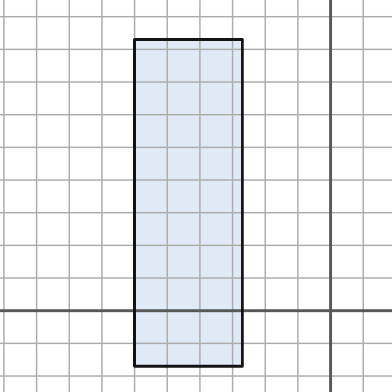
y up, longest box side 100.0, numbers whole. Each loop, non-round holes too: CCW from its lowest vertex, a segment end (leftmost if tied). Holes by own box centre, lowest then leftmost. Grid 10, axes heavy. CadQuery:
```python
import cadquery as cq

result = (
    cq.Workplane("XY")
    .moveTo(-60.0, -17.0)
    .lineTo(-27.0, -17.0)
    .lineTo(-27.0, 83.0)
    .lineTo(-60.0, 83.0)
    .close()
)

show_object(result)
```